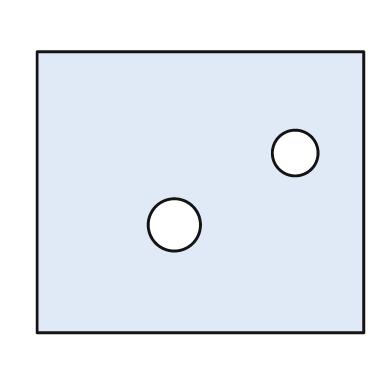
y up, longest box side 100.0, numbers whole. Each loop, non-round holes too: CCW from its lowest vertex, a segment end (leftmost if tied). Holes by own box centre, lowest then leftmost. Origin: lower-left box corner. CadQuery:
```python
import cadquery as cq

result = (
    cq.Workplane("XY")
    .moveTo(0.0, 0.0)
    .lineTo(100.0, 0.0)
    .lineTo(100.0, 86.0)
    .lineTo(0.0, 86.0)
    .close()
    .moveTo(42.0, 33.0)
    .circle(8.0)
    .moveTo(79.0, 55.0)
    .circle(7.0)
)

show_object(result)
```